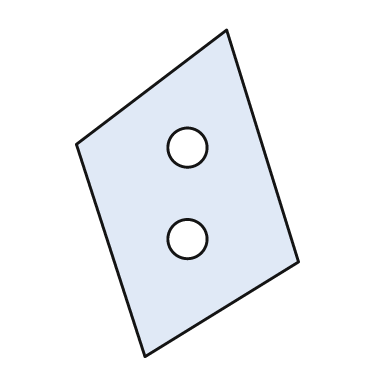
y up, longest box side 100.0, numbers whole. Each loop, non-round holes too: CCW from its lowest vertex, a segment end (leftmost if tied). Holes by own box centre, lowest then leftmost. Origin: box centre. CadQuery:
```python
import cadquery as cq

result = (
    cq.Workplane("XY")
    .moveTo(-13.0, -50.0)
    .lineTo(34.0, -21.0)
    .lineTo(12.0, 50.0)
    .lineTo(-34.0, 15.0)
    .close()
    .moveTo(0.0, -14.0)
    .circle(6.0)
    .moveTo(0.0, 14.0)
    .circle(6.0)
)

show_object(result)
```